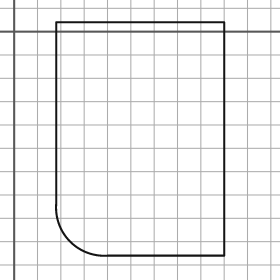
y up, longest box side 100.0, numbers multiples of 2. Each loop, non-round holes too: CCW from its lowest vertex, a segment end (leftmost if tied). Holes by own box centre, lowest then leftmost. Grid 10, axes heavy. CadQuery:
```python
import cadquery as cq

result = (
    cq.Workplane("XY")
    .moveTo(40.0, -96.0)
    .lineTo(90.0, -96.0)
    .lineTo(90.0, 4.0)
    .lineTo(18.0, 4.0)
    .lineTo(18.0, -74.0)
    .threePointArc((24.0, -90.0), (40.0, -96.0))
    .close()
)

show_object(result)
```